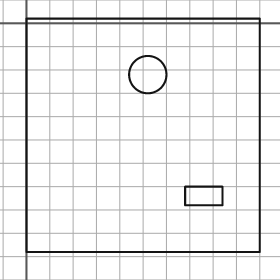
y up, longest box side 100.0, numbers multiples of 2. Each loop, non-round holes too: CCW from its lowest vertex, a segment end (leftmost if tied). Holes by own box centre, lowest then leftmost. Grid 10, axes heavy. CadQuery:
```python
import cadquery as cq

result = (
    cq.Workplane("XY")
    .moveTo(0.0, -98.0)
    .lineTo(100.0, -98.0)
    .lineTo(100.0, 2.0)
    .lineTo(0.0, 2.0)
    .close()
    .moveTo(68.0, -78.0)
    .lineTo(84.0, -78.0)
    .lineTo(84.0, -70.0)
    .lineTo(68.0, -70.0)
    .close()
    .moveTo(52.0, -22.0)
    .circle(8.0)
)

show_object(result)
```